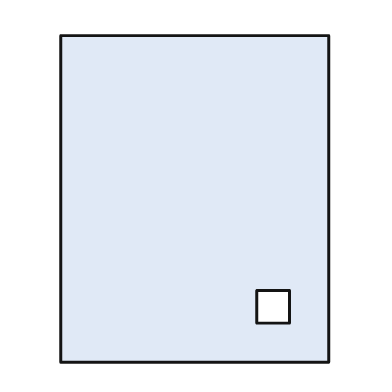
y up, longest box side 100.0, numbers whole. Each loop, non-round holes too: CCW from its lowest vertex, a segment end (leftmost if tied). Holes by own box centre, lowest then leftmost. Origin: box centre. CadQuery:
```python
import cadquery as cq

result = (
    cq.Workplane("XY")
    .moveTo(-41.0, -50.0)
    .lineTo(41.0, -50.0)
    .lineTo(41.0, 50.0)
    .lineTo(-41.0, 50.0)
    .close()
    .moveTo(19.0, -38.0)
    .lineTo(29.0, -38.0)
    .lineTo(29.0, -28.0)
    .lineTo(19.0, -28.0)
    .close()
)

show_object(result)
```